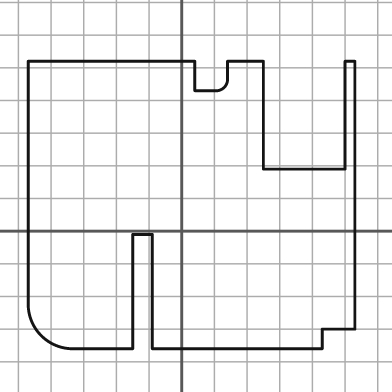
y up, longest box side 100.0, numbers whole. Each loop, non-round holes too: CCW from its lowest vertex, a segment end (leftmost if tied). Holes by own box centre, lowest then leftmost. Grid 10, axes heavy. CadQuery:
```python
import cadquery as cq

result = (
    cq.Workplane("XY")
    .moveTo(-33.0, -36.0)
    .lineTo(-15.0, -36.0)
    .lineTo(-15.0, -1.0)
    .lineTo(-9.0, -1.0)
    .lineTo(-9.0, -36.0)
    .lineTo(43.0, -36.0)
    .lineTo(43.0, -30.0)
    .lineTo(53.0, -30.0)
    .lineTo(53.0, 52.0)
    .lineTo(50.0, 52.0)
    .lineTo(50.0, 19.0)
    .lineTo(25.0, 19.0)
    .lineTo(25.0, 52.0)
    .lineTo(14.0, 52.0)
    .lineTo(14.0, 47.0)
    .threePointArc((13.0, 44.0), (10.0, 43.0))
    .lineTo(4.0, 43.0)
    .lineTo(4.0, 52.0)
    .lineTo(-47.0, 52.0)
    .lineTo(-47.0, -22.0)
    .threePointArc((-43.0, -32.0), (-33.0, -36.0))
    .close()
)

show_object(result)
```